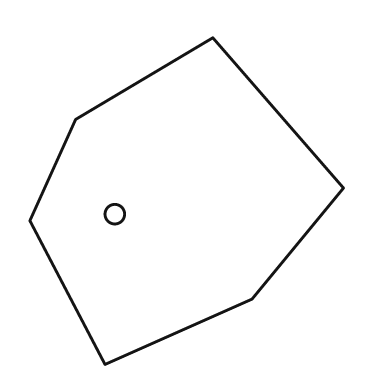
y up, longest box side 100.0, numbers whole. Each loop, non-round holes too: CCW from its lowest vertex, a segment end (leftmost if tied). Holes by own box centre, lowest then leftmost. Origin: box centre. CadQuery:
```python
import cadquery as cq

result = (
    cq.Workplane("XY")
    .moveTo(-25.0, -50.0)
    .lineTo(20.0, -30.0)
    .lineTo(48.0, 4.0)
    .lineTo(8.0, 50.0)
    .lineTo(-34.0, 25.0)
    .lineTo(-48.0, -6.0)
    .close()
    .moveTo(-22.0, -4.0)
    .circle(3.0)
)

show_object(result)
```